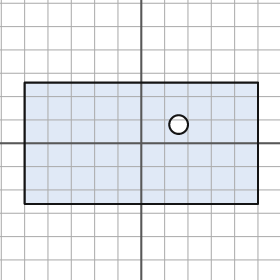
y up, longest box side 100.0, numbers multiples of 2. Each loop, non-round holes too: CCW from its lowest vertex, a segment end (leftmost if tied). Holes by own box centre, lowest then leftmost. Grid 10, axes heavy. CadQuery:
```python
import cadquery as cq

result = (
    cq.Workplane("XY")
    .moveTo(-50.0, -26.0)
    .lineTo(50.0, -26.0)
    .lineTo(50.0, 26.0)
    .lineTo(-50.0, 26.0)
    .close()
    .moveTo(16.0, 8.0)
    .circle(4.0)
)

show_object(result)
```